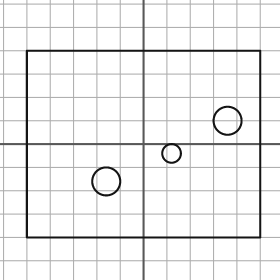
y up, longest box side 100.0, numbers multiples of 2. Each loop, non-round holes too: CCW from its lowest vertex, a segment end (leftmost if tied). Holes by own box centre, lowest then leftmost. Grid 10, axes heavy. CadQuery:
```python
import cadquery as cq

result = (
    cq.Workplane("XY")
    .moveTo(-50.0, -40.0)
    .lineTo(50.0, -40.0)
    .lineTo(50.0, 40.0)
    .lineTo(-50.0, 40.0)
    .close()
    .moveTo(-16.0, -16.0)
    .circle(6.0)
    .moveTo(12.0, -4.0)
    .circle(4.0)
    .moveTo(36.0, 10.0)
    .circle(6.0)
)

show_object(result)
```